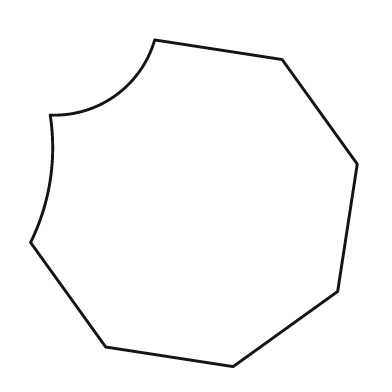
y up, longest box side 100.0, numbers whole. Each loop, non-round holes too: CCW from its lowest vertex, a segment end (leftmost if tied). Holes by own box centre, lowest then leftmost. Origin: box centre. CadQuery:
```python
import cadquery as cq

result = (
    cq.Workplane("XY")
    .moveTo(12.0, -50.0)
    .lineTo(44.0, -27.0)
    .lineTo(50.0, 12.0)
    .lineTo(27.0, 44.0)
    .lineTo(-12.0, 50.0)
    .threePointArc((-24.0, 33.0), (-44.0, 27.0))
    .threePointArc((-44.0, 7.0), (-50.0, -12.0))
    .lineTo(-27.0, -44.0)
    .close()
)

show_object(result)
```